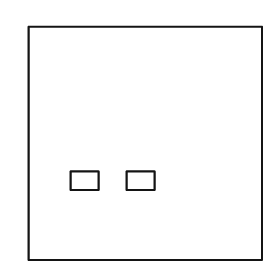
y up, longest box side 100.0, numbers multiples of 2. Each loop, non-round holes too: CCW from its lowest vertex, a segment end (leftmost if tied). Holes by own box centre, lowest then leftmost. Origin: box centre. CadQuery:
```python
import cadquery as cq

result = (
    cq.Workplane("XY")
    .moveTo(-50.0, -50.0)
    .lineTo(50.0, -50.0)
    .lineTo(50.0, 50.0)
    .lineTo(-50.0, 50.0)
    .close()
    .moveTo(-32.0, -20.0)
    .lineTo(-20.0, -20.0)
    .lineTo(-20.0, -12.0)
    .lineTo(-32.0, -12.0)
    .close()
    .moveTo(-8.0, -20.0)
    .lineTo(4.0, -20.0)
    .lineTo(4.0, -12.0)
    .lineTo(-8.0, -12.0)
    .close()
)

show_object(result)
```